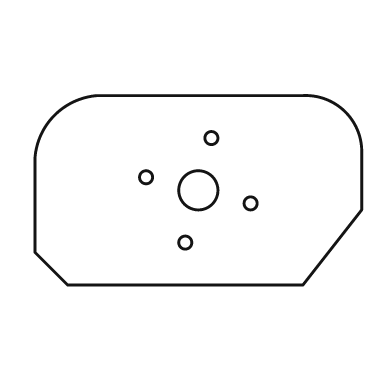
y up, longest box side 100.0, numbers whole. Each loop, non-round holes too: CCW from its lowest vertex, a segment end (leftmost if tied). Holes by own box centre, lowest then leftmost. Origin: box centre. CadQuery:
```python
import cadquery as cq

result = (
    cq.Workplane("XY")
    .moveTo(-40.0, -29.0)
    .lineTo(32.0, -29.0)
    .lineTo(50.0, -6.0)
    .lineTo(50.0, 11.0)
    .threePointArc((45.0, 24.0), (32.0, 29.0))
    .lineTo(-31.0, 29.0)
    .threePointArc((-44.0, 23.0), (-50.0, 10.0))
    .lineTo(-50.0, -19.0)
    .close()
    .moveTo(-4.0, -16.0)
    .circle(2.0)
    .moveTo(16.0, -4.0)
    .circle(2.0)
    .moveTo(0.0, 0.0)
    .circle(6.0)
    .moveTo(-16.0, 4.0)
    .circle(2.0)
    .moveTo(4.0, 16.0)
    .circle(2.0)
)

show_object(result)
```